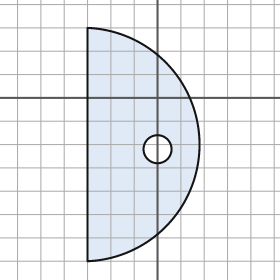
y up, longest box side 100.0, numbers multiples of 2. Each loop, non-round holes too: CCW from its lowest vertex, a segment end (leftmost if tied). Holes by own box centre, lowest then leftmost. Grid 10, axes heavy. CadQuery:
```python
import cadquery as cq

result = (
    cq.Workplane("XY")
    .moveTo(-30.0, -70.0)
    .threePointArc((18.0, -20.0), (-30.0, 30.0))
    .close()
    .moveTo(0.0, -22.0)
    .circle(6.0)
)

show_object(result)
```